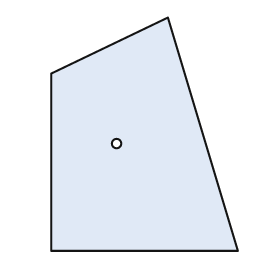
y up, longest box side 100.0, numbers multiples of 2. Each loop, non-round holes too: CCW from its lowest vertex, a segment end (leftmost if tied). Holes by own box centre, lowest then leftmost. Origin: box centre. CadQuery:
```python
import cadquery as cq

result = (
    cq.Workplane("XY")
    .moveTo(-40.0, -50.0)
    .lineTo(40.0, -50.0)
    .lineTo(10.0, 50.0)
    .lineTo(-40.0, 26.0)
    .close()
    .moveTo(-12.0, -4.0)
    .circle(2.0)
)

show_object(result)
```